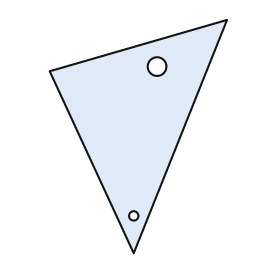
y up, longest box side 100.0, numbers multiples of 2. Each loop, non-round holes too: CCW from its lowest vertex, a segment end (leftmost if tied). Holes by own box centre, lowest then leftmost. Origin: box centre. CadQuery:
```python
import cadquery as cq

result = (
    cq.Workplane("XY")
    .moveTo(-2.0, -50.0)
    .lineTo(38.0, 50.0)
    .lineTo(-38.0, 28.0)
    .close()
    .moveTo(-2.0, -34.0)
    .circle(2.0)
    .moveTo(8.0, 30.0)
    .circle(4.0)
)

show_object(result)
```